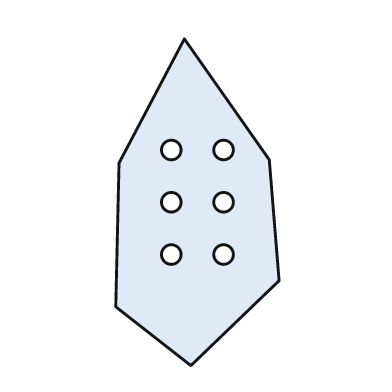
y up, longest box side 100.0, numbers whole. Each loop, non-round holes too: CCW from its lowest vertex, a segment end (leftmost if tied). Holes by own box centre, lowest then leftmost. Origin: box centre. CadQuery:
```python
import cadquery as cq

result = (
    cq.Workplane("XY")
    .moveTo(-2.0, -50.0)
    .lineTo(25.0, -24.0)
    .lineTo(22.0, 13.0)
    .lineTo(-4.0, 50.0)
    .lineTo(-24.0, 12.0)
    .lineTo(-25.0, -32.0)
    .close()
    .moveTo(-8.0, -16.0)
    .circle(3.0)
    .moveTo(8.0, -16.0)
    .circle(3.0)
    .moveTo(-8.0, 0.0)
    .circle(3.0)
    .moveTo(8.0, 0.0)
    .circle(3.0)
    .moveTo(-8.0, 16.0)
    .circle(3.0)
    .moveTo(8.0, 16.0)
    .circle(3.0)
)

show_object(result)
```